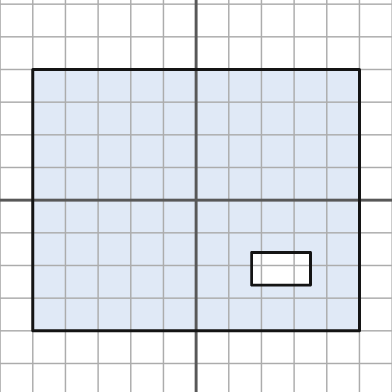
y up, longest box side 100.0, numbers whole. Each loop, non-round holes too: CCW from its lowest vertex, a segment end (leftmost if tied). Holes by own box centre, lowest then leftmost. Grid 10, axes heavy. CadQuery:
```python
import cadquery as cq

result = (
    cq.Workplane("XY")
    .moveTo(-50.0, -40.0)
    .lineTo(50.0, -40.0)
    .lineTo(50.0, 40.0)
    .lineTo(-50.0, 40.0)
    .close()
    .moveTo(17.0, -26.0)
    .lineTo(35.0, -26.0)
    .lineTo(35.0, -16.0)
    .lineTo(17.0, -16.0)
    .close()
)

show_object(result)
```